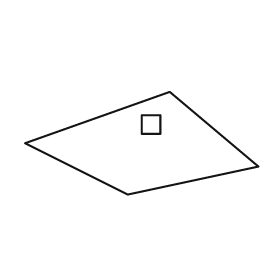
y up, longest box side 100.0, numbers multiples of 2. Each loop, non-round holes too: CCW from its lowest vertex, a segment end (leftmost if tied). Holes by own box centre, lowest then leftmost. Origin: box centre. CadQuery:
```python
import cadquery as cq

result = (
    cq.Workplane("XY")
    .moveTo(-6.0, -22.0)
    .lineTo(50.0, -10.0)
    .lineTo(12.0, 22.0)
    .lineTo(-50.0, 0.0)
    .close()
    .moveTo(0.0, 4.0)
    .lineTo(8.0, 4.0)
    .lineTo(8.0, 12.0)
    .lineTo(0.0, 12.0)
    .close()
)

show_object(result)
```